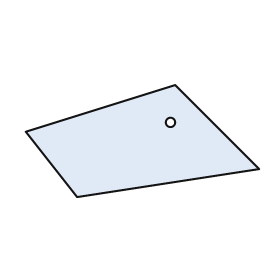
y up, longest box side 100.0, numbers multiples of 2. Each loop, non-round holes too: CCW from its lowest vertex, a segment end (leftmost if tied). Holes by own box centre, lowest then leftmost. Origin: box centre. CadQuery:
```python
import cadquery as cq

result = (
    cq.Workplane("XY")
    .moveTo(-28.0, -24.0)
    .lineTo(50.0, -12.0)
    .lineTo(14.0, 24.0)
    .lineTo(-50.0, 4.0)
    .close()
    .moveTo(12.0, 8.0)
    .circle(2.0)
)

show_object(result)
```